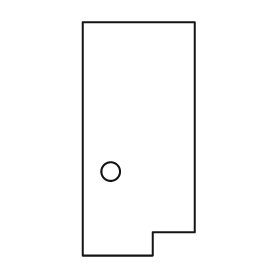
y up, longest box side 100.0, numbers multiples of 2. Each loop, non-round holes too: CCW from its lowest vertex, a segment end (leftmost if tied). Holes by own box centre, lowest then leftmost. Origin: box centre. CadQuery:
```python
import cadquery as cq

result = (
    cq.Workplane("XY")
    .moveTo(-24.0, -50.0)
    .lineTo(6.0, -50.0)
    .lineTo(6.0, -40.0)
    .lineTo(24.0, -40.0)
    .lineTo(24.0, 50.0)
    .lineTo(-24.0, 50.0)
    .close()
    .moveTo(-12.0, -14.0)
    .circle(4.0)
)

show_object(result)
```